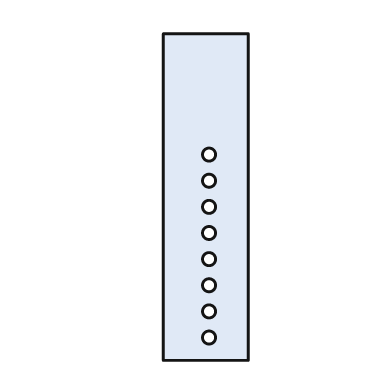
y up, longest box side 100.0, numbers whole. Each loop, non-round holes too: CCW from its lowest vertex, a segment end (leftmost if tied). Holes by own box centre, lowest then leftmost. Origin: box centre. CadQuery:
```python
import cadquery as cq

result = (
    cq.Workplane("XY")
    .moveTo(-13.0, -50.0)
    .lineTo(13.0, -50.0)
    .lineTo(13.0, 50.0)
    .lineTo(-13.0, 50.0)
    .close()
    .moveTo(1.0, -43.0)
    .circle(2.0)
    .moveTo(1.0, -35.0)
    .circle(2.0)
    .moveTo(1.0, -27.0)
    .circle(2.0)
    .moveTo(1.0, -19.0)
    .circle(2.0)
    .moveTo(1.0, -11.0)
    .circle(2.0)
    .moveTo(1.0, -3.0)
    .circle(2.0)
    .moveTo(1.0, 5.0)
    .circle(2.0)
    .moveTo(1.0, 13.0)
    .circle(2.0)
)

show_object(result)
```